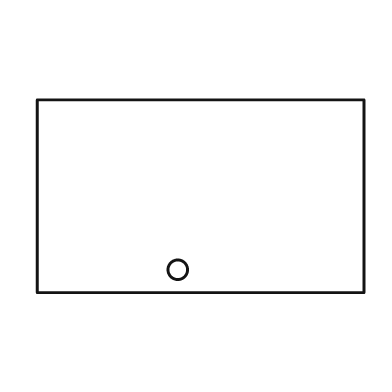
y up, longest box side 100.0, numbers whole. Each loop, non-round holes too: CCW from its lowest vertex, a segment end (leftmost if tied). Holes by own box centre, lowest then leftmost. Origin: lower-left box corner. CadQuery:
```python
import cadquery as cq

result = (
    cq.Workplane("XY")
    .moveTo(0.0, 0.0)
    .lineTo(100.0, 0.0)
    .lineTo(100.0, 59.0)
    .lineTo(0.0, 59.0)
    .close()
    .moveTo(43.0, 7.0)
    .circle(3.0)
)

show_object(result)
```